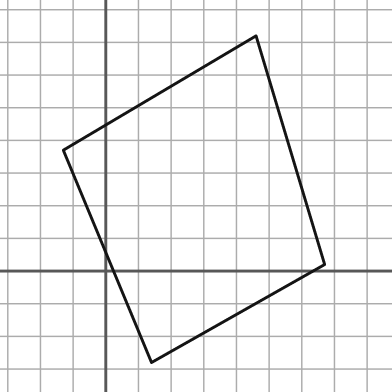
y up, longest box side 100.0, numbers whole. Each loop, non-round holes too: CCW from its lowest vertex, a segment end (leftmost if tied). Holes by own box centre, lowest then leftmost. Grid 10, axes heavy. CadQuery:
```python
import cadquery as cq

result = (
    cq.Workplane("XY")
    .moveTo(14.0, -28.0)
    .lineTo(67.0, 2.0)
    .lineTo(46.0, 72.0)
    .lineTo(-13.0, 37.0)
    .close()
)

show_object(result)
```